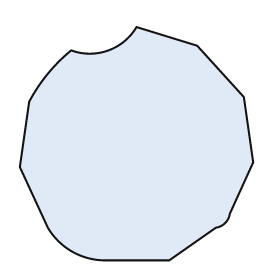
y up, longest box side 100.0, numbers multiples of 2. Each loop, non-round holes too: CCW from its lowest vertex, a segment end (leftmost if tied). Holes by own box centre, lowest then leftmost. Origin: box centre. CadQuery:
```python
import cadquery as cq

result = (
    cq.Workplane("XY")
    .moveTo(-14.0, -50.0)
    .lineTo(14.0, -50.0)
    .lineTo(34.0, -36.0)
    .threePointArc((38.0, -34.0), (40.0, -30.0))
    .lineTo(50.0, -8.0)
    .lineTo(46.0, 20.0)
    .lineTo(26.0, 42.0)
    .lineTo(0.0, 50.0)
    .threePointArc((-12.0, 40.0), (-28.0, 40.0))
    .threePointArc((-38.0, 30.0), (-46.0, 18.0))
    .lineTo(-50.0, -10.0)
    .lineTo(-38.0, -36.0)
    .threePointArc((-28.0, -46.0), (-14.0, -50.0))
    .close()
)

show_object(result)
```